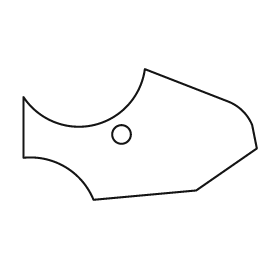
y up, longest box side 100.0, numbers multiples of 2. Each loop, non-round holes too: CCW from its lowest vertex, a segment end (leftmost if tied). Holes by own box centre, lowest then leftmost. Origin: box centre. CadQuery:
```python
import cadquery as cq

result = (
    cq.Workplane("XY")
    .moveTo(-20.0, -28.0)
    .lineTo(24.0, -24.0)
    .lineTo(50.0, -6.0)
    .lineTo(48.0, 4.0)
    .threePointArc((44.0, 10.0), (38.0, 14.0))
    .lineTo(2.0, 28.0)
    .threePointArc((-20.0, 4.0), (-50.0, 16.0))
    .lineTo(-50.0, -10.0)
    .threePointArc((-32.0, -14.0), (-20.0, -28.0))
    .close()
    .moveTo(-8.0, 0.0)
    .circle(4.0)
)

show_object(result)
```